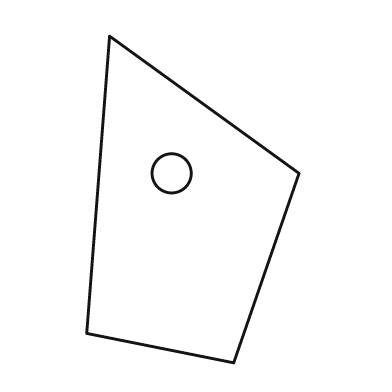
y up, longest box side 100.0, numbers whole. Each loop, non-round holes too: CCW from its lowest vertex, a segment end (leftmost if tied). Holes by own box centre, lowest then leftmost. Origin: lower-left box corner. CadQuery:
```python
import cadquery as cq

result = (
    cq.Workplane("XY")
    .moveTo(45.0, 0.0)
    .lineTo(65.0, 58.0)
    .lineTo(7.0, 100.0)
    .lineTo(0.0, 9.0)
    .close()
    .moveTo(26.0, 58.0)
    .circle(6.0)
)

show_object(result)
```